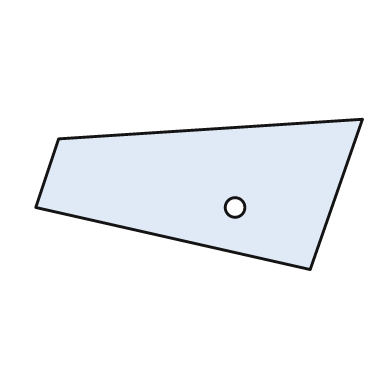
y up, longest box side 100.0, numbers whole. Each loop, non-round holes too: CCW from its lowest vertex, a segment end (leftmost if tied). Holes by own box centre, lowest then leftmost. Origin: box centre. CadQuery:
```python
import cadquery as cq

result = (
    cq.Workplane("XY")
    .moveTo(34.0, -23.0)
    .lineTo(50.0, 23.0)
    .lineTo(-43.0, 17.0)
    .lineTo(-50.0, -4.0)
    .close()
    .moveTo(11.0, -4.0)
    .circle(3.0)
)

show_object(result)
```